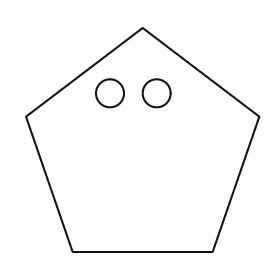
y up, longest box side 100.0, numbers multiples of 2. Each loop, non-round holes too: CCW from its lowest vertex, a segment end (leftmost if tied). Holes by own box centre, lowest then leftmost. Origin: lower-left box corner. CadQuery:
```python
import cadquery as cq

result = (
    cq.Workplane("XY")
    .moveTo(20.0, 0.0)
    .lineTo(80.0, 0.0)
    .lineTo(100.0, 58.0)
    .lineTo(50.0, 96.0)
    .lineTo(0.0, 58.0)
    .close()
    .moveTo(36.0, 68.0)
    .circle(6.0)
    .moveTo(56.0, 68.0)
    .circle(6.0)
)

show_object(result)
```